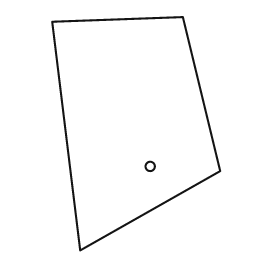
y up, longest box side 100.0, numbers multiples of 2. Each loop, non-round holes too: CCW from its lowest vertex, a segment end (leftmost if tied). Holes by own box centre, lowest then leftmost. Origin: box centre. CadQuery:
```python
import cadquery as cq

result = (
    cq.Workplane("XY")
    .moveTo(-24.0, -50.0)
    .lineTo(36.0, -16.0)
    .lineTo(20.0, 50.0)
    .lineTo(-36.0, 48.0)
    .close()
    .moveTo(6.0, -14.0)
    .circle(2.0)
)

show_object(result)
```